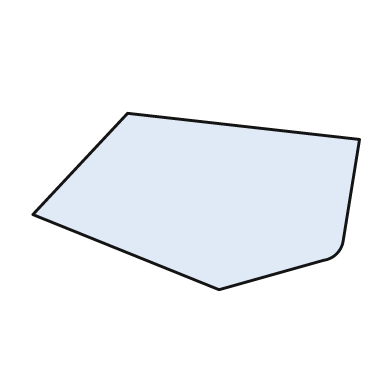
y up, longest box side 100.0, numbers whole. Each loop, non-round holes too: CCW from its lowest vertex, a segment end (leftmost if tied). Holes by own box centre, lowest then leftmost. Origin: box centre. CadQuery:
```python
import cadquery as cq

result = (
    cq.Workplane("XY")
    .moveTo(7.0, -27.0)
    .lineTo(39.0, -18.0)
    .threePointArc((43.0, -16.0), (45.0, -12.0))
    .lineTo(50.0, 19.0)
    .lineTo(-21.0, 27.0)
    .lineTo(-50.0, -4.0)
    .close()
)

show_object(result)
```